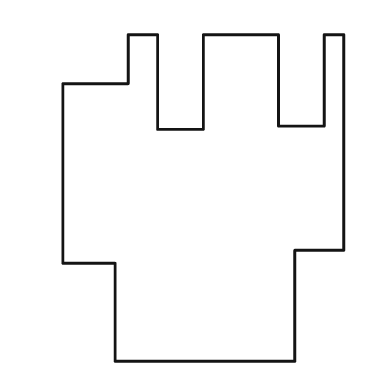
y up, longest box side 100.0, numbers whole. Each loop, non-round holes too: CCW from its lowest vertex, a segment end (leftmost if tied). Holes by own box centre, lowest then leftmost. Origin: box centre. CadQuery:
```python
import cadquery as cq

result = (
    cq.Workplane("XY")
    .moveTo(-27.0, -50.0)
    .lineTo(28.0, -50.0)
    .lineTo(28.0, -16.0)
    .lineTo(43.0, -16.0)
    .lineTo(43.0, 50.0)
    .lineTo(37.0, 50.0)
    .lineTo(37.0, 22.0)
    .lineTo(23.0, 22.0)
    .lineTo(23.0, 50.0)
    .lineTo(0.0, 50.0)
    .lineTo(0.0, 21.0)
    .lineTo(-14.0, 21.0)
    .lineTo(-14.0, 50.0)
    .lineTo(-23.0, 50.0)
    .lineTo(-23.0, 35.0)
    .lineTo(-43.0, 35.0)
    .lineTo(-43.0, -20.0)
    .lineTo(-27.0, -20.0)
    .close()
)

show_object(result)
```